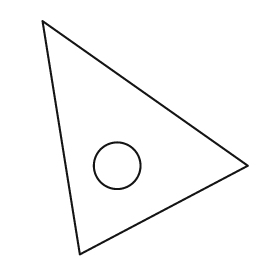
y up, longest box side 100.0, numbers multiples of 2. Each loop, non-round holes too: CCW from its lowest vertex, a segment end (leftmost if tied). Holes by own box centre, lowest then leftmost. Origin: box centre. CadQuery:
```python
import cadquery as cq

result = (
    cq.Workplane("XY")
    .moveTo(-28.0, -50.0)
    .lineTo(44.0, -12.0)
    .lineTo(-44.0, 50.0)
    .close()
    .moveTo(-12.0, -12.0)
    .circle(10.0)
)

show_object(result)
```